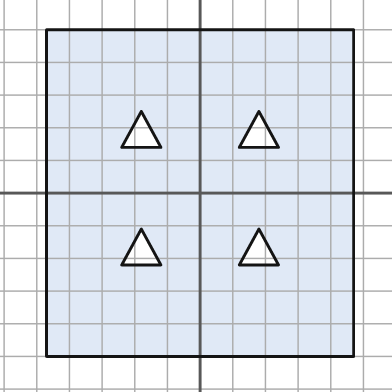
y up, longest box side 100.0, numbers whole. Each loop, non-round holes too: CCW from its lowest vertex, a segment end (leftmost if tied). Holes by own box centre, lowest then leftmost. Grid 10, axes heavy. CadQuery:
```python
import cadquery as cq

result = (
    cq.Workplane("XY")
    .moveTo(-47.0, -50.0)
    .lineTo(47.0, -50.0)
    .lineTo(47.0, 50.0)
    .lineTo(-47.0, 50.0)
    .close()
    .moveTo(-24.0, -22.0)
    .lineTo(-12.0, -22.0)
    .lineTo(-18.0, -11.0)
    .close()
    .moveTo(12.0, -22.0)
    .lineTo(24.0, -22.0)
    .lineTo(18.0, -11.0)
    .close()
    .moveTo(-24.0, 14.0)
    .lineTo(-12.0, 14.0)
    .lineTo(-18.0, 25.0)
    .close()
    .moveTo(12.0, 14.0)
    .lineTo(24.0, 14.0)
    .lineTo(18.0, 25.0)
    .close()
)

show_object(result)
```